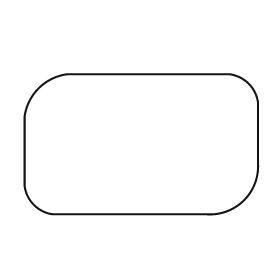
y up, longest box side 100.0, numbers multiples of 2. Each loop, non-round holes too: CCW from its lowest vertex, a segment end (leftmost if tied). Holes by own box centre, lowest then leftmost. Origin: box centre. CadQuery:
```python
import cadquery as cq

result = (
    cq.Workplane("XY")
    .moveTo(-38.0, -30.0)
    .lineTo(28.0, -30.0)
    .threePointArc((44.0, -24.0), (50.0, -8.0))
    .lineTo(50.0, 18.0)
    .threePointArc((46.0, 26.0), (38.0, 30.0))
    .lineTo(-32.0, 30.0)
    .threePointArc((-44.0, 24.0), (-50.0, 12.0))
    .lineTo(-50.0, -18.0)
    .threePointArc((-46.0, -26.0), (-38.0, -30.0))
    .close()
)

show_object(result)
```